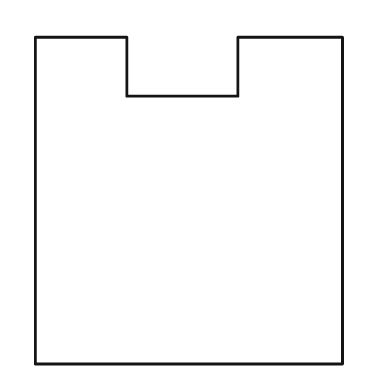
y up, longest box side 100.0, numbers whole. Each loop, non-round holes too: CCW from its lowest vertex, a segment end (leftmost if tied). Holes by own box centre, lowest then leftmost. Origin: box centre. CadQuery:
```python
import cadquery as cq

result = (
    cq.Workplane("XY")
    .moveTo(-47.0, -50.0)
    .lineTo(47.0, -50.0)
    .lineTo(47.0, 50.0)
    .lineTo(15.0, 50.0)
    .lineTo(15.0, 32.0)
    .lineTo(-19.0, 32.0)
    .lineTo(-19.0, 50.0)
    .lineTo(-47.0, 50.0)
    .close()
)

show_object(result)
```